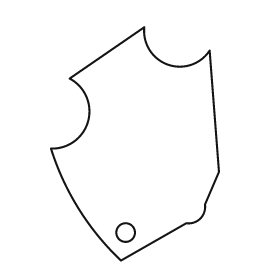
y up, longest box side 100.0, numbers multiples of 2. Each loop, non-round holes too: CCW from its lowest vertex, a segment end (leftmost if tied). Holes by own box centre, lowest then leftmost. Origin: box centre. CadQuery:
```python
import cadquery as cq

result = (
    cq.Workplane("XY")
    .moveTo(-6.0, -50.0)
    .lineTo(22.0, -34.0)
    .threePointArc((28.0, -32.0), (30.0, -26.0))
    .lineTo(36.0, -12.0)
    .lineTo(32.0, 40.0)
    .threePointArc((14.0, 34.0), (4.0, 50.0))
    .lineTo(-28.0, 28.0)
    .threePointArc((-20.0, 10.0), (-36.0, -2.0))
    .threePointArc((-24.0, -28.0), (-6.0, -50.0))
    .close()
    .moveTo(-4.0, -38.0)
    .circle(4.0)
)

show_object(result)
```